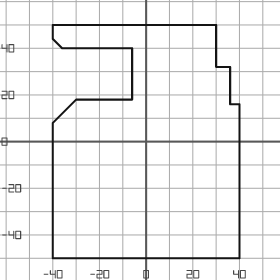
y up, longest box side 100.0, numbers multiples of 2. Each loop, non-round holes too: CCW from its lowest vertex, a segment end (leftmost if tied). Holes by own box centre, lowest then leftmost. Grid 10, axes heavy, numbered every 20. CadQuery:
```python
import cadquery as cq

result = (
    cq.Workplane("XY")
    .moveTo(-40.0, -50.0)
    .lineTo(40.0, -50.0)
    .lineTo(40.0, 16.0)
    .lineTo(36.0, 16.0)
    .lineTo(36.0, 32.0)
    .lineTo(30.0, 32.0)
    .lineTo(30.0, 50.0)
    .lineTo(-40.0, 50.0)
    .lineTo(-40.0, 44.0)
    .lineTo(-36.0, 40.0)
    .lineTo(-6.0, 40.0)
    .lineTo(-6.0, 18.0)
    .lineTo(-30.0, 18.0)
    .lineTo(-40.0, 8.0)
    .close()
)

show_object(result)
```